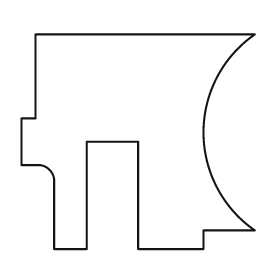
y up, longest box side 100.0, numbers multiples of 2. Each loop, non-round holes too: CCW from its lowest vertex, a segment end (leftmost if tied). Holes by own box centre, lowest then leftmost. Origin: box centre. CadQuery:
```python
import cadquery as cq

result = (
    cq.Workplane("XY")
    .moveTo(-36.0, -46.0)
    .lineTo(-22.0, -46.0)
    .lineTo(-22.0, 0.0)
    .lineTo(0.0, 0.0)
    .lineTo(0.0, -46.0)
    .lineTo(28.0, -46.0)
    .lineTo(28.0, -38.0)
    .lineTo(50.0, -38.0)
    .threePointArc((28.0, 4.0), (50.0, 46.0))
    .lineTo(-44.0, 46.0)
    .lineTo(-44.0, 10.0)
    .lineTo(-50.0, 10.0)
    .lineTo(-50.0, -10.0)
    .lineTo(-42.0, -10.0)
    .threePointArc((-38.0, -12.0), (-36.0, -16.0))
    .close()
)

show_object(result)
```